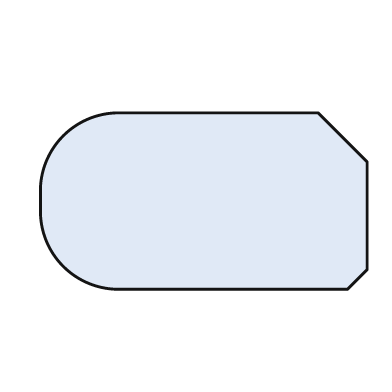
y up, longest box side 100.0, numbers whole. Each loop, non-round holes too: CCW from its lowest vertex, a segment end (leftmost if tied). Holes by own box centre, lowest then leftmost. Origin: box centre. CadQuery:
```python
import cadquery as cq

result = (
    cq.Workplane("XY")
    .moveTo(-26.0, -27.0)
    .lineTo(44.0, -27.0)
    .lineTo(50.0, -21.0)
    .lineTo(50.0, 12.0)
    .lineTo(35.0, 27.0)
    .lineTo(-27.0, 27.0)
    .threePointArc((-43.0, 20.0), (-50.0, 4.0))
    .lineTo(-50.0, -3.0)
    .threePointArc((-43.0, -20.0), (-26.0, -27.0))
    .close()
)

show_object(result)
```